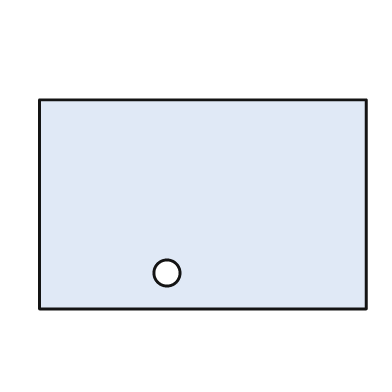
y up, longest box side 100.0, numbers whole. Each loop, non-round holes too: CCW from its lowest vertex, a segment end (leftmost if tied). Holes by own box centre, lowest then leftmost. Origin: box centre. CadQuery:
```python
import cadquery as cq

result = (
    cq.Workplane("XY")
    .moveTo(-50.0, -32.0)
    .lineTo(50.0, -32.0)
    .lineTo(50.0, 32.0)
    .lineTo(-50.0, 32.0)
    .close()
    .moveTo(-11.0, -21.0)
    .circle(4.0)
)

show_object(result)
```